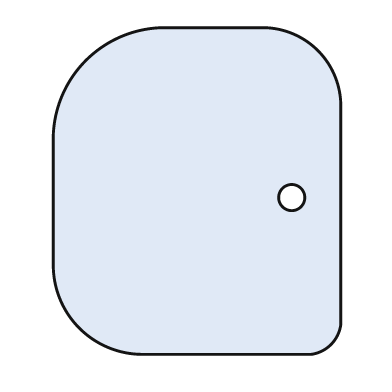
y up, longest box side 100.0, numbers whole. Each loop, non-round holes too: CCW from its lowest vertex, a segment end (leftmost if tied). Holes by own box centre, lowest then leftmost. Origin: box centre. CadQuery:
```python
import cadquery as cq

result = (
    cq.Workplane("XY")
    .moveTo(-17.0, -50.0)
    .lineTo(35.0, -50.0)
    .threePointArc((41.0, -47.0), (44.0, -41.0))
    .lineTo(44.0, 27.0)
    .threePointArc((37.0, 43.0), (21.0, 50.0))
    .lineTo(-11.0, 50.0)
    .threePointArc((-34.0, 40.0), (-44.0, 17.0))
    .lineTo(-44.0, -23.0)
    .threePointArc((-36.0, -42.0), (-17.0, -50.0))
    .close()
    .moveTo(29.0, -2.0)
    .circle(4.0)
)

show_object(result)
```